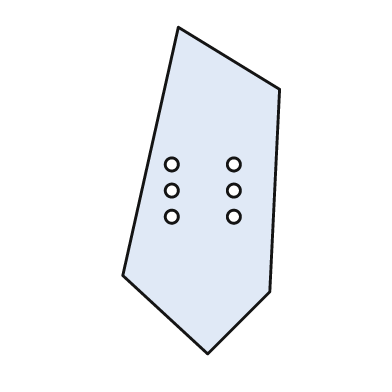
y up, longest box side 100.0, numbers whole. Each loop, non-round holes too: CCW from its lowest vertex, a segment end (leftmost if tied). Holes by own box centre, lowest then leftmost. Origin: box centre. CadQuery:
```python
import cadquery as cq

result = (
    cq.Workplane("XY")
    .moveTo(2.0, -50.0)
    .lineTo(21.0, -31.0)
    .lineTo(24.0, 31.0)
    .lineTo(-7.0, 50.0)
    .lineTo(-24.0, -26.0)
    .close()
    .moveTo(-9.0, -8.0)
    .circle(2.0)
    .moveTo(10.0, -8.0)
    .circle(2.0)
    .moveTo(-9.0, 0.0)
    .circle(2.0)
    .moveTo(10.0, 0.0)
    .circle(2.0)
    .moveTo(-9.0, 8.0)
    .circle(2.0)
    .moveTo(10.0, 8.0)
    .circle(2.0)
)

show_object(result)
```